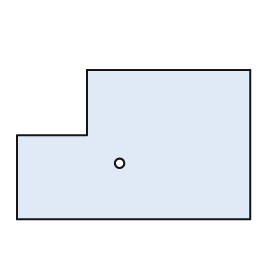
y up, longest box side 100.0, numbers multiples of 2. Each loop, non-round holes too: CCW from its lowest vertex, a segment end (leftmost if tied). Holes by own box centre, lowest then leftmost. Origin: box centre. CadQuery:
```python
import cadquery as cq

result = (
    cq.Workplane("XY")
    .moveTo(-50.0, -32.0)
    .lineTo(50.0, -32.0)
    .lineTo(50.0, 32.0)
    .lineTo(-20.0, 32.0)
    .lineTo(-20.0, 4.0)
    .lineTo(-50.0, 4.0)
    .close()
    .moveTo(-6.0, -8.0)
    .circle(2.0)
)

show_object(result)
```